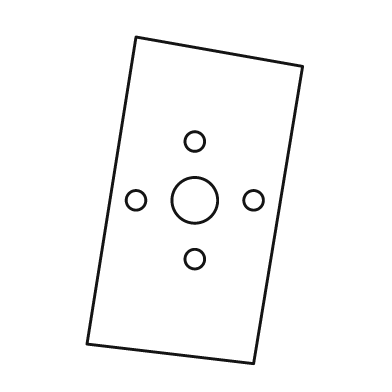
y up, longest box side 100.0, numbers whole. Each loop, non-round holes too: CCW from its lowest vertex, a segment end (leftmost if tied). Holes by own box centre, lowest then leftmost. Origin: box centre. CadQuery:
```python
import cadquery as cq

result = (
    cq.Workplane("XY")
    .moveTo(18.0, -50.0)
    .lineTo(33.0, 41.0)
    .lineTo(-18.0, 50.0)
    .lineTo(-33.0, -44.0)
    .close()
    .moveTo(0.0, -18.0)
    .circle(3.0)
    .moveTo(-18.0, 0.0)
    .circle(3.0)
    .moveTo(0.0, 0.0)
    .circle(7.0)
    .moveTo(18.0, 0.0)
    .circle(3.0)
    .moveTo(0.0, 18.0)
    .circle(3.0)
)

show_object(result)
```